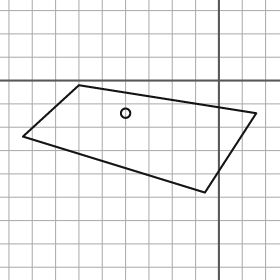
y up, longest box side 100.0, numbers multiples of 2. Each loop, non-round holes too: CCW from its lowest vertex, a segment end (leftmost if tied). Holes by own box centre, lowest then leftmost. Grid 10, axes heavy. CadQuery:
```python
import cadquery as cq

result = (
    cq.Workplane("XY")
    .moveTo(-6.0, -48.0)
    .lineTo(16.0, -14.0)
    .lineTo(-60.0, -2.0)
    .lineTo(-84.0, -24.0)
    .close()
    .moveTo(-40.0, -14.0)
    .circle(2.0)
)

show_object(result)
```